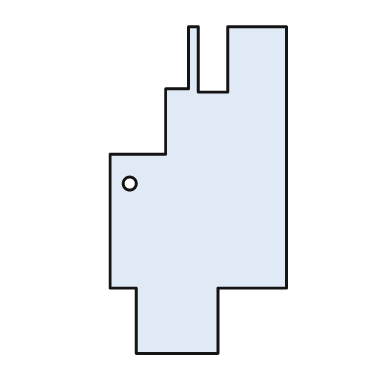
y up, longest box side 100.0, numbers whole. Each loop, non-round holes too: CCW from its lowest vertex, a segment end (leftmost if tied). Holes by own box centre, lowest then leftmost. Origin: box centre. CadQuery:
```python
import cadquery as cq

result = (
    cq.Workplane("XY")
    .moveTo(-19.0, -50.0)
    .lineTo(6.0, -50.0)
    .lineTo(6.0, -30.0)
    .lineTo(27.0, -30.0)
    .lineTo(27.0, 50.0)
    .lineTo(9.0, 50.0)
    .lineTo(9.0, 30.0)
    .lineTo(0.0, 30.0)
    .lineTo(0.0, 50.0)
    .lineTo(-3.0, 50.0)
    .lineTo(-3.0, 31.0)
    .lineTo(-10.0, 31.0)
    .lineTo(-10.0, 11.0)
    .lineTo(-27.0, 11.0)
    .lineTo(-27.0, -30.0)
    .lineTo(-19.0, -30.0)
    .close()
    .moveTo(-21.0, 2.0)
    .circle(2.0)
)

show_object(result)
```